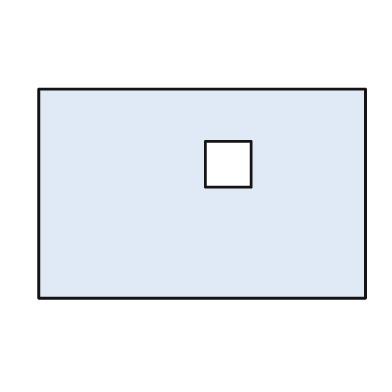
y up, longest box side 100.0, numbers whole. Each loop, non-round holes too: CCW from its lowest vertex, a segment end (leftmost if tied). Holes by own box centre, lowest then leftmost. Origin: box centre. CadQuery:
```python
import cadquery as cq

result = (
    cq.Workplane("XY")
    .moveTo(-50.0, -32.0)
    .lineTo(50.0, -32.0)
    .lineTo(50.0, 32.0)
    .lineTo(-50.0, 32.0)
    .close()
    .moveTo(1.0, 2.0)
    .lineTo(15.0, 2.0)
    .lineTo(15.0, 16.0)
    .lineTo(1.0, 16.0)
    .close()
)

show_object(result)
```